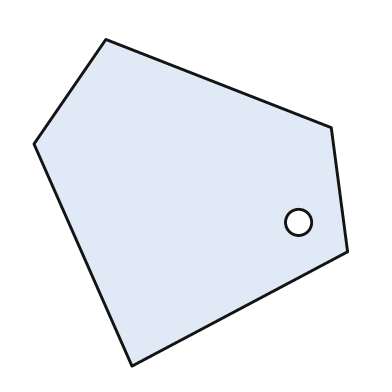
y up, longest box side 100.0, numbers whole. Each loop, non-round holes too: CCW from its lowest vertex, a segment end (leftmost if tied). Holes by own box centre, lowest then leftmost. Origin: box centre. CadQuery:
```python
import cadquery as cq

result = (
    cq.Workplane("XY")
    .moveTo(-18.0, -50.0)
    .lineTo(48.0, -15.0)
    .lineTo(43.0, 23.0)
    .lineTo(-26.0, 50.0)
    .lineTo(-48.0, 18.0)
    .close()
    .moveTo(33.0, -6.0)
    .circle(4.0)
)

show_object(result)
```